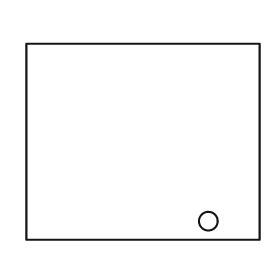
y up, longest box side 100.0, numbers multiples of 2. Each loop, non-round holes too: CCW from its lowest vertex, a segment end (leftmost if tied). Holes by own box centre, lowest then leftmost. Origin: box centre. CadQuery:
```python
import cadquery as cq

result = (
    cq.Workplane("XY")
    .moveTo(-50.0, -42.0)
    .lineTo(50.0, -42.0)
    .lineTo(50.0, 42.0)
    .lineTo(-50.0, 42.0)
    .close()
    .moveTo(28.0, -34.0)
    .circle(4.0)
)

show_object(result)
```